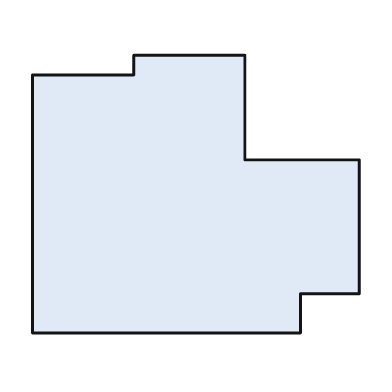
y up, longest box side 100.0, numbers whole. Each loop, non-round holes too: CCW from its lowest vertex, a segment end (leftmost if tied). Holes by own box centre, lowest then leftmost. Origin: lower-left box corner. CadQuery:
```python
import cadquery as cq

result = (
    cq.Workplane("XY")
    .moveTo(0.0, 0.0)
    .lineTo(82.0, 0.0)
    .lineTo(82.0, 12.0)
    .lineTo(100.0, 12.0)
    .lineTo(100.0, 53.0)
    .lineTo(65.0, 53.0)
    .lineTo(65.0, 85.0)
    .lineTo(31.0, 85.0)
    .lineTo(31.0, 79.0)
    .lineTo(0.0, 79.0)
    .close()
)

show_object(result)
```